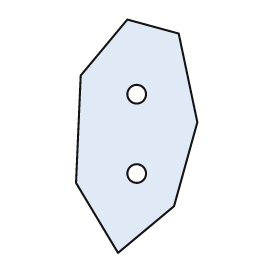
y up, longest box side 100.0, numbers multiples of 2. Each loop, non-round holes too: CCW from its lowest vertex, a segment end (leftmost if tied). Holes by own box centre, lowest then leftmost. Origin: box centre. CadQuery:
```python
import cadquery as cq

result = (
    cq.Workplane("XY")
    .moveTo(-8.0, -50.0)
    .lineTo(16.0, -30.0)
    .lineTo(26.0, 6.0)
    .lineTo(18.0, 44.0)
    .lineTo(-4.0, 50.0)
    .lineTo(-24.0, 26.0)
    .lineTo(-26.0, -20.0)
    .close()
    .moveTo(0.0, -16.0)
    .circle(4.0)
    .moveTo(0.0, 18.0)
    .circle(4.0)
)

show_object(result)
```